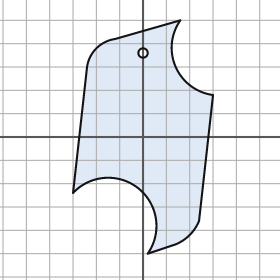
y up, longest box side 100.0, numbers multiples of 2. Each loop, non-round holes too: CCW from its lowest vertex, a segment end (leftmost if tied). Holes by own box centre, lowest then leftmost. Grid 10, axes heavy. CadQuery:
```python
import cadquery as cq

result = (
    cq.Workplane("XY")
    .moveTo(2.0, -50.0)
    .lineTo(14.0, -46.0)
    .threePointArc((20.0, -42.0), (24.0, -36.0))
    .lineTo(30.0, 18.0)
    .threePointArc((14.0, 30.0), (16.0, 50.0))
    .lineTo(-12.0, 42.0)
    .threePointArc((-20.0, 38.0), (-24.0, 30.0))
    .lineTo(-30.0, -24.0)
    .threePointArc((-2.0, -22.0), (2.0, -50.0))
    .close()
    .moveTo(0.0, 36.0)
    .circle(2.0)
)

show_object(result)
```